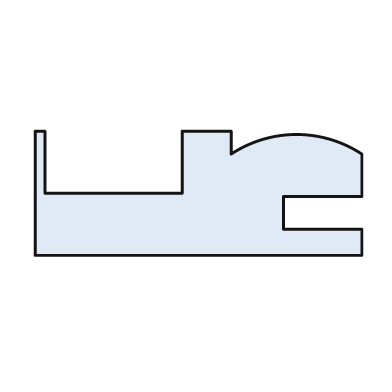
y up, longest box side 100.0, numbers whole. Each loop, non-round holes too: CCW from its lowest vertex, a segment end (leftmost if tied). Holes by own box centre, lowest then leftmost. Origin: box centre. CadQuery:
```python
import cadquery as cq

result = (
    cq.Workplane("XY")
    .moveTo(-50.0, -19.0)
    .lineTo(50.0, -19.0)
    .lineTo(50.0, -11.0)
    .lineTo(26.0, -11.0)
    .lineTo(26.0, -1.0)
    .lineTo(50.0, -1.0)
    .lineTo(50.0, 12.0)
    .threePointArc((30.0, 18.0), (10.0, 12.0))
    .lineTo(10.0, 19.0)
    .lineTo(-5.0, 19.0)
    .lineTo(-5.0, 0.0)
    .lineTo(-47.0, 0.0)
    .lineTo(-47.0, 19.0)
    .lineTo(-50.0, 19.0)
    .close()
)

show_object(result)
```